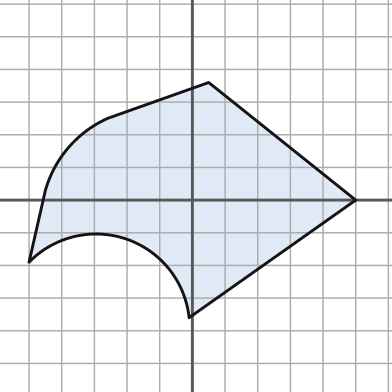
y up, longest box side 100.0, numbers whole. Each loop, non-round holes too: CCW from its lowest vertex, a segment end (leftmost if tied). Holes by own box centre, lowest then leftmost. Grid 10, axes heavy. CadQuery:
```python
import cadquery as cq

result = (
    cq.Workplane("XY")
    .moveTo(-1.0, -36.0)
    .lineTo(50.0, 0.0)
    .lineTo(5.0, 36.0)
    .lineTo(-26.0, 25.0)
    .threePointArc((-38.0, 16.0), (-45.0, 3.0))
    .lineTo(-50.0, -19.0)
    .threePointArc((-20.0, -12.0), (-1.0, -36.0))
    .close()
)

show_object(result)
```